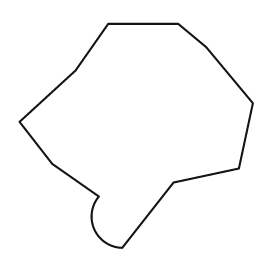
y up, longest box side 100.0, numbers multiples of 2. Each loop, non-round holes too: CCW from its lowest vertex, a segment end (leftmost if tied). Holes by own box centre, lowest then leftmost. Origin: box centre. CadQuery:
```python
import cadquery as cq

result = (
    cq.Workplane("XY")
    .moveTo(-6.0, -48.0)
    .lineTo(16.0, -20.0)
    .lineTo(44.0, -14.0)
    .lineTo(50.0, 14.0)
    .lineTo(30.0, 38.0)
    .lineTo(18.0, 48.0)
    .lineTo(-12.0, 48.0)
    .lineTo(-26.0, 28.0)
    .lineTo(-50.0, 6.0)
    .lineTo(-36.0, -12.0)
    .lineTo(-16.0, -26.0)
    .threePointArc((-18.0, -40.0), (-6.0, -48.0))
    .close()
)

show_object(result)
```